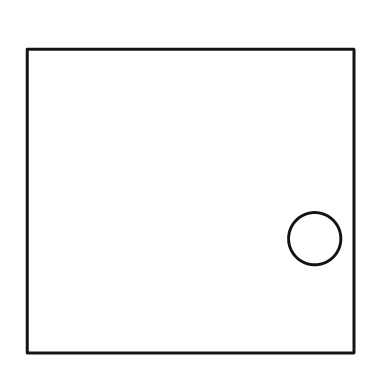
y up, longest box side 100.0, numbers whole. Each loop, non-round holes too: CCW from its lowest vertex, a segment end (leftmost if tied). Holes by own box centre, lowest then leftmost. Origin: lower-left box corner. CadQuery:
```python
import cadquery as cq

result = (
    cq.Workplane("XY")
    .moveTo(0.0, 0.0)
    .lineTo(100.0, 0.0)
    .lineTo(100.0, 93.0)
    .lineTo(0.0, 93.0)
    .close()
    .moveTo(88.0, 35.0)
    .circle(8.0)
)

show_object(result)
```